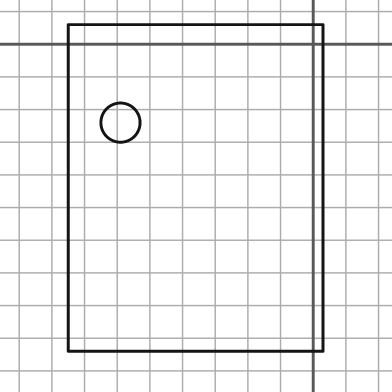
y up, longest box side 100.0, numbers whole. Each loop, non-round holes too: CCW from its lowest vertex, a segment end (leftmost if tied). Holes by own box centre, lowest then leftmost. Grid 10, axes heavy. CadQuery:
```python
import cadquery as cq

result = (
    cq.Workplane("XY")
    .moveTo(-75.0, -94.0)
    .lineTo(3.0, -94.0)
    .lineTo(3.0, 6.0)
    .lineTo(-75.0, 6.0)
    .close()
    .moveTo(-59.0, -24.0)
    .circle(6.0)
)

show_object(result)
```